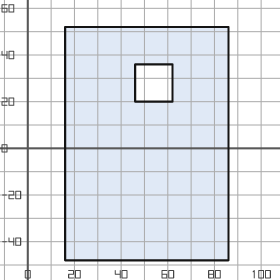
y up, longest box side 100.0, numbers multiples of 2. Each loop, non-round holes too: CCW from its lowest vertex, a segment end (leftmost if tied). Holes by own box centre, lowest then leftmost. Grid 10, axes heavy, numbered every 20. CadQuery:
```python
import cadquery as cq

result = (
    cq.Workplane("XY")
    .moveTo(16.0, -48.0)
    .lineTo(86.0, -48.0)
    .lineTo(86.0, 52.0)
    .lineTo(16.0, 52.0)
    .close()
    .moveTo(46.0, 20.0)
    .lineTo(62.0, 20.0)
    .lineTo(62.0, 36.0)
    .lineTo(46.0, 36.0)
    .close()
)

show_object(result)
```